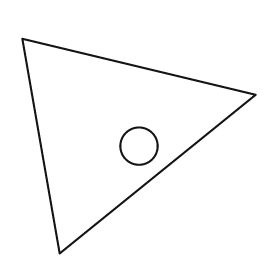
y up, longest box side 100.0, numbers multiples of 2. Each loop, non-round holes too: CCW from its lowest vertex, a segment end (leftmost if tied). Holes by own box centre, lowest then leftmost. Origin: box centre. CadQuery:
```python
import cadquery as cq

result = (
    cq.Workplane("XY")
    .moveTo(-34.0, -46.0)
    .lineTo(50.0, 22.0)
    .lineTo(-50.0, 46.0)
    .close()
    .moveTo(0.0, 0.0)
    .circle(8.0)
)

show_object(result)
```